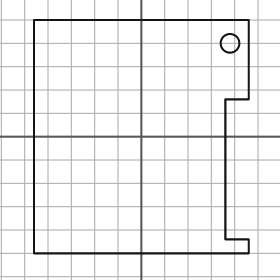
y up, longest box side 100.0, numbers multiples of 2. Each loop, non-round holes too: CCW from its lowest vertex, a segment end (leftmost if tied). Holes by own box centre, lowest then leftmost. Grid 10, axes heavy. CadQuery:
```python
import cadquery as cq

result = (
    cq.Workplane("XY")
    .moveTo(-46.0, -50.0)
    .lineTo(46.0, -50.0)
    .lineTo(46.0, -44.0)
    .lineTo(36.0, -44.0)
    .lineTo(36.0, 16.0)
    .lineTo(46.0, 16.0)
    .lineTo(46.0, 50.0)
    .lineTo(-46.0, 50.0)
    .close()
    .moveTo(38.0, 40.0)
    .circle(4.0)
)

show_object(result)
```